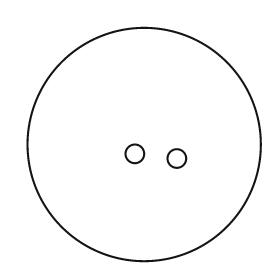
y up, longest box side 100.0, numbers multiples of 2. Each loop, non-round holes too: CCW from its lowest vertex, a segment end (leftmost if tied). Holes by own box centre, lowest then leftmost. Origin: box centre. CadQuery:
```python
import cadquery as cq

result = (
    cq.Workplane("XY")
    .moveTo(0.0, 0.0)
    .circle(50.0)
    .moveTo(14.0, -6.0)
    .circle(4.0)
    .moveTo(-4.0, -4.0)
    .circle(4.0)
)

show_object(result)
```